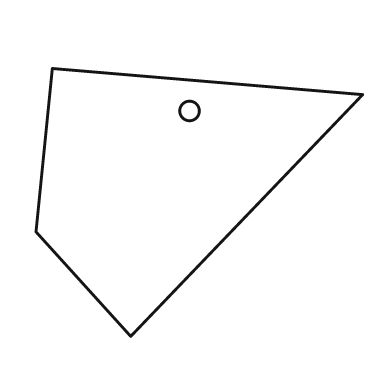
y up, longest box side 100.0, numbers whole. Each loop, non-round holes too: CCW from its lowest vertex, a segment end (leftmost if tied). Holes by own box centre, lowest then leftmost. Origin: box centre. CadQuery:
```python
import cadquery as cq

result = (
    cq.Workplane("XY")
    .moveTo(-21.0, -41.0)
    .lineTo(50.0, 33.0)
    .lineTo(-45.0, 41.0)
    .lineTo(-50.0, -9.0)
    .close()
    .moveTo(-3.0, 28.0)
    .circle(3.0)
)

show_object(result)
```